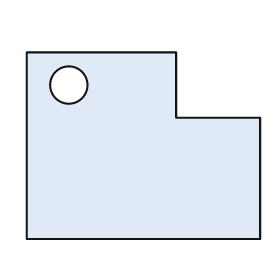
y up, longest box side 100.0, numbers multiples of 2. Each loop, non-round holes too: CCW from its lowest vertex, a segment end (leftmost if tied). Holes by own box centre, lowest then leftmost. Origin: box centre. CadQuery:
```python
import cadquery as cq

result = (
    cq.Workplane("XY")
    .moveTo(-50.0, -40.0)
    .lineTo(50.0, -40.0)
    .lineTo(50.0, 12.0)
    .lineTo(14.0, 12.0)
    .lineTo(14.0, 40.0)
    .lineTo(-50.0, 40.0)
    .close()
    .moveTo(-32.0, 26.0)
    .circle(8.0)
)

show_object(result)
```